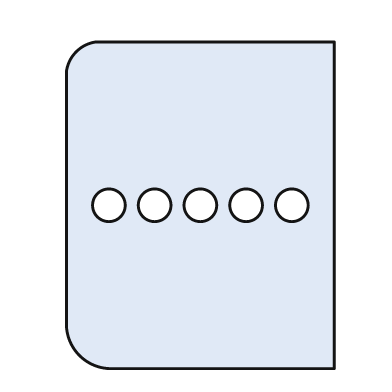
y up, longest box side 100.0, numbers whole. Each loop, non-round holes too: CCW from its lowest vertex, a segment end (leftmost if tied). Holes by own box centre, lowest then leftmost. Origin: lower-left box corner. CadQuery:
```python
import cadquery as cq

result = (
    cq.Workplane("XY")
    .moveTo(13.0, 0.0)
    .lineTo(82.0, 0.0)
    .lineTo(82.0, 100.0)
    .lineTo(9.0, 100.0)
    .threePointArc((3.0, 97.0), (0.0, 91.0))
    .lineTo(0.0, 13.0)
    .threePointArc((4.0, 4.0), (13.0, 0.0))
    .close()
    .moveTo(13.0, 50.0)
    .circle(5.0)
    .moveTo(27.0, 50.0)
    .circle(5.0)
    .moveTo(41.0, 50.0)
    .circle(5.0)
    .moveTo(55.0, 50.0)
    .circle(5.0)
    .moveTo(69.0, 50.0)
    .circle(5.0)
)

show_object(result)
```